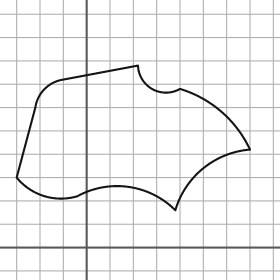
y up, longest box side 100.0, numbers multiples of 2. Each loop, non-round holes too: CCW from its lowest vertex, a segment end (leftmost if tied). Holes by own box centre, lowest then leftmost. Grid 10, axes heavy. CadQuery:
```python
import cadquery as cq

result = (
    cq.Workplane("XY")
    .moveTo(38.0, 16.0)
    .threePointArc((50.0, 34.0), (70.0, 42.0))
    .threePointArc((58.0, 58.0), (40.0, 68.0))
    .threePointArc((28.0, 68.0), (22.0, 78.0))
    .lineTo(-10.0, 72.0)
    .threePointArc((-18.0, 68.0), (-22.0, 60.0))
    .lineTo(-30.0, 30.0)
    .threePointArc((-18.0, 22.0), (-4.0, 22.0))
    .threePointArc((18.0, 26.0), (38.0, 16.0))
    .close()
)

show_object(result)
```